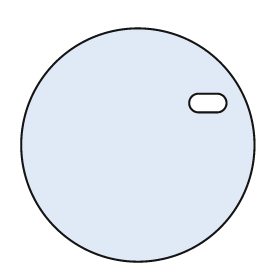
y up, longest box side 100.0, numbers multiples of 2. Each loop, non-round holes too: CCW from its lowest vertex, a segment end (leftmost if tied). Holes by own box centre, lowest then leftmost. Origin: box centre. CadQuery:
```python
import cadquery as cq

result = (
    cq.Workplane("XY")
    .moveTo(0.0, 0.0)
    .circle(50.0)
    .moveTo(26.0, 14.0)
    .lineTo(34.0, 14.0)
    .threePointArc((38.0, 18.0), (34.0, 22.0))
    .lineTo(26.0, 22.0)
    .threePointArc((22.0, 18.0), (26.0, 14.0))
    .close()
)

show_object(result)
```